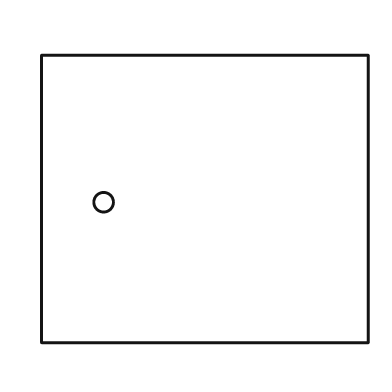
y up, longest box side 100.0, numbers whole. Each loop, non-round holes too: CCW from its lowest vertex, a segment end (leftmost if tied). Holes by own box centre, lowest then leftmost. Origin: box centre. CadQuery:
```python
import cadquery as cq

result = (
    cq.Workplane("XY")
    .moveTo(-50.0, -44.0)
    .lineTo(50.0, -44.0)
    .lineTo(50.0, 44.0)
    .lineTo(-50.0, 44.0)
    .close()
    .moveTo(-31.0, -1.0)
    .circle(3.0)
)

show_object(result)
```